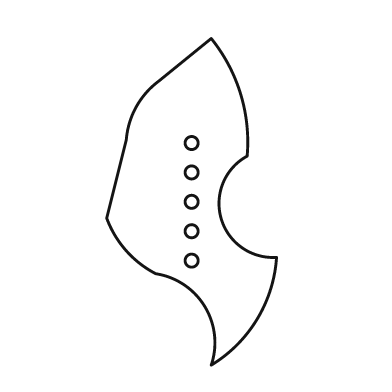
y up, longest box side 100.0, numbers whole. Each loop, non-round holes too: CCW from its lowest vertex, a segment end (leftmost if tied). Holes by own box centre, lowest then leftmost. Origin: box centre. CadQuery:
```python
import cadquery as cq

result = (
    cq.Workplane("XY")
    .moveTo(6.0, -50.0)
    .threePointArc((20.0, -36.0), (26.0, -17.0))
    .threePointArc((9.0, -5.0), (17.0, 14.0))
    .threePointArc((15.0, 33.0), (6.0, 50.0))
    .lineTo(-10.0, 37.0)
    .threePointArc((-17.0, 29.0), (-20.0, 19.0))
    .lineTo(-26.0, -5.0)
    .threePointArc((-20.0, -15.0), (-11.0, -22.0))
    .threePointArc((4.0, -32.0), (6.0, -50.0))
    .close()
    .moveTo(0.0, -18.0)
    .circle(2.0)
    .moveTo(0.0, -9.0)
    .circle(2.0)
    .moveTo(0.0, 0.0)
    .circle(2.0)
    .moveTo(0.0, 9.0)
    .circle(2.0)
    .moveTo(0.0, 18.0)
    .circle(2.0)
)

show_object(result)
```